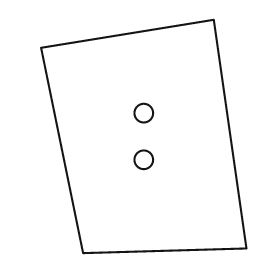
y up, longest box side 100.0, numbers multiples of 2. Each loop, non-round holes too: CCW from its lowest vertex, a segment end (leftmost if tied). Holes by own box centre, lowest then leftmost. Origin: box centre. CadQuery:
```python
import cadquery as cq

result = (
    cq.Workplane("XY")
    .moveTo(-26.0, -50.0)
    .lineTo(44.0, -48.0)
    .lineTo(30.0, 50.0)
    .lineTo(-44.0, 38.0)
    .close()
    .moveTo(0.0, -10.0)
    .circle(4.0)
    .moveTo(0.0, 10.0)
    .circle(4.0)
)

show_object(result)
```